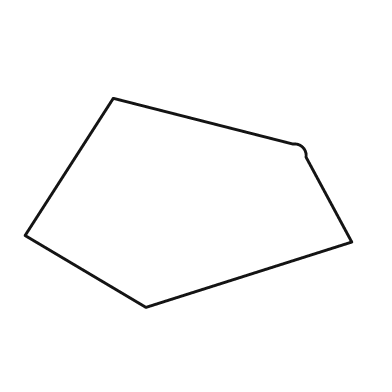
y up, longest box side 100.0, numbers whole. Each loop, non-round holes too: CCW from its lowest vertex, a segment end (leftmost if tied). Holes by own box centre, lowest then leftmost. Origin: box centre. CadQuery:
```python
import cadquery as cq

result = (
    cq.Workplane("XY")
    .moveTo(-13.0, -32.0)
    .lineTo(50.0, -12.0)
    .lineTo(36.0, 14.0)
    .threePointArc((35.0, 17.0), (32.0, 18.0))
    .lineTo(-23.0, 32.0)
    .lineTo(-50.0, -10.0)
    .close()
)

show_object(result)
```